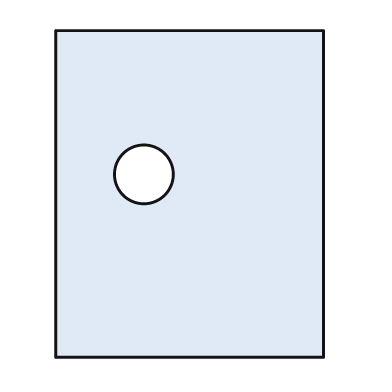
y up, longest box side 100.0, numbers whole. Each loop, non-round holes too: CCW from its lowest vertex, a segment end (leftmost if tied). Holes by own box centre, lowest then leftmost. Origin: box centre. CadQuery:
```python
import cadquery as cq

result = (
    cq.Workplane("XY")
    .moveTo(-41.0, -50.0)
    .lineTo(41.0, -50.0)
    .lineTo(41.0, 50.0)
    .lineTo(-41.0, 50.0)
    .close()
    .moveTo(-14.0, 6.0)
    .circle(9.0)
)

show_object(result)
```